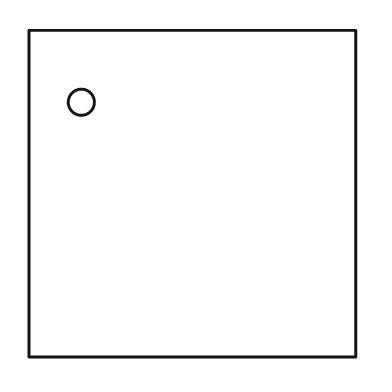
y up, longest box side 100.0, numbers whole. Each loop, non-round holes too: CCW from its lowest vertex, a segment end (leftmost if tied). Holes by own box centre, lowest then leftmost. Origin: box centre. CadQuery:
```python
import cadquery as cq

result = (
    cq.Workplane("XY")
    .moveTo(-50.0, -50.0)
    .lineTo(50.0, -50.0)
    .lineTo(50.0, 50.0)
    .lineTo(-50.0, 50.0)
    .close()
    .moveTo(-34.0, 28.0)
    .circle(4.0)
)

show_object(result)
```